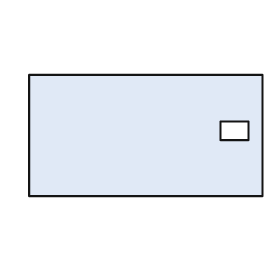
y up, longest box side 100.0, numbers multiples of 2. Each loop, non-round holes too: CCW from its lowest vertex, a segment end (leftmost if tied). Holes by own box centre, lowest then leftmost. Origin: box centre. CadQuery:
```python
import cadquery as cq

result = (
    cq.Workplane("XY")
    .moveTo(-50.0, -26.0)
    .lineTo(50.0, -26.0)
    .lineTo(50.0, 26.0)
    .lineTo(-50.0, 26.0)
    .close()
    .moveTo(32.0, -2.0)
    .lineTo(44.0, -2.0)
    .lineTo(44.0, 6.0)
    .lineTo(32.0, 6.0)
    .close()
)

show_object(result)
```